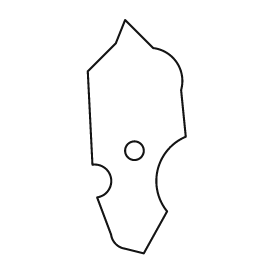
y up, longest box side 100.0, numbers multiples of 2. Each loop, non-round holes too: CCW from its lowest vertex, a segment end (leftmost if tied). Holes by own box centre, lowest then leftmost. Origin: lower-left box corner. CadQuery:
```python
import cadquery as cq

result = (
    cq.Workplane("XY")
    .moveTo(24.0, 0.0)
    .lineTo(34.0, 18.0)
    .threePointArc((30.0, 36.0), (42.0, 50.0))
    .lineTo(40.0, 70.0)
    .threePointArc((38.0, 82.0), (28.0, 88.0))
    .lineTo(16.0, 100.0)
    .lineTo(12.0, 90.0)
    .lineTo(0.0, 78.0)
    .lineTo(2.0, 38.0)
    .threePointArc((10.0, 32.0), (4.0, 24.0))
    .lineTo(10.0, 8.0)
    .threePointArc((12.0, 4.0), (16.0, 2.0))
    .close()
    .moveTo(20.0, 44.0)
    .circle(4.0)
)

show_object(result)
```